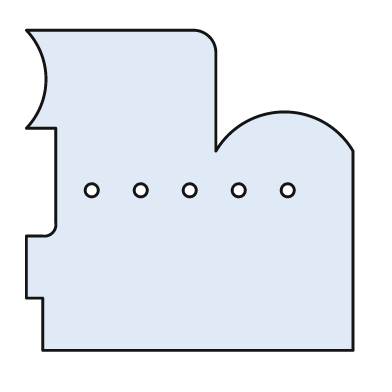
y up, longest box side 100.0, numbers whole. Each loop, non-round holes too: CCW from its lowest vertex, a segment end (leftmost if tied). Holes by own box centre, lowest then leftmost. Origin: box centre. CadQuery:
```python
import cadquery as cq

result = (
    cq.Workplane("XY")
    .moveTo(-45.0, -49.0)
    .lineTo(50.0, -49.0)
    .lineTo(50.0, 12.0)
    .threePointArc((29.0, 24.0), (8.0, 12.0))
    .lineTo(8.0, 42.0)
    .threePointArc((6.0, 47.0), (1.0, 49.0))
    .lineTo(-50.0, 49.0)
    .threePointArc((-44.0, 34.0), (-50.0, 19.0))
    .lineTo(-41.0, 19.0)
    .lineTo(-41.0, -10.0)
    .threePointArc((-42.0, -13.0), (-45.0, -14.0))
    .lineTo(-50.0, -14.0)
    .lineTo(-50.0, -33.0)
    .lineTo(-45.0, -33.0)
    .close()
    .moveTo(-30.0, 0.0)
    .circle(2.0)
    .moveTo(-15.0, 0.0)
    .circle(2.0)
    .moveTo(0.0, 0.0)
    .circle(2.0)
    .moveTo(15.0, 0.0)
    .circle(2.0)
    .moveTo(30.0, 0.0)
    .circle(2.0)
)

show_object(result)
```